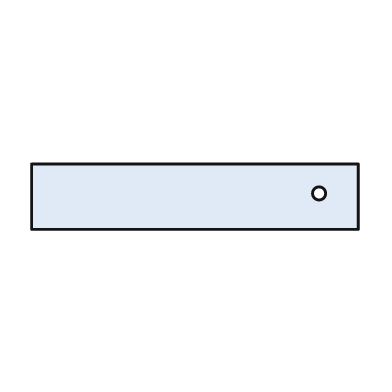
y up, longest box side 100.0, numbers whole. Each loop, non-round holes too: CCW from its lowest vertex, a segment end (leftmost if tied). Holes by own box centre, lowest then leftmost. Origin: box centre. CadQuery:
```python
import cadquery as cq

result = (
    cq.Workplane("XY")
    .moveTo(-50.0, -10.0)
    .lineTo(50.0, -10.0)
    .lineTo(50.0, 10.0)
    .lineTo(-50.0, 10.0)
    .close()
    .moveTo(38.0, 1.0)
    .circle(2.0)
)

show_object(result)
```